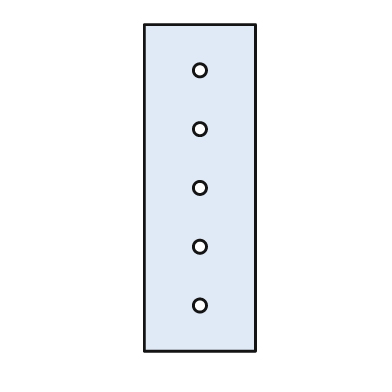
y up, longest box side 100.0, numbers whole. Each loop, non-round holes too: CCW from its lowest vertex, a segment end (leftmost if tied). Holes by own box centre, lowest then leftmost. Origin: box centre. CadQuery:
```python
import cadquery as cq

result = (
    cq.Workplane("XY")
    .moveTo(-17.0, -50.0)
    .lineTo(17.0, -50.0)
    .lineTo(17.0, 50.0)
    .lineTo(-17.0, 50.0)
    .close()
    .moveTo(0.0, -36.0)
    .circle(2.0)
    .moveTo(0.0, -18.0)
    .circle(2.0)
    .moveTo(0.0, 0.0)
    .circle(2.0)
    .moveTo(0.0, 18.0)
    .circle(2.0)
    .moveTo(0.0, 36.0)
    .circle(2.0)
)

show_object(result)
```